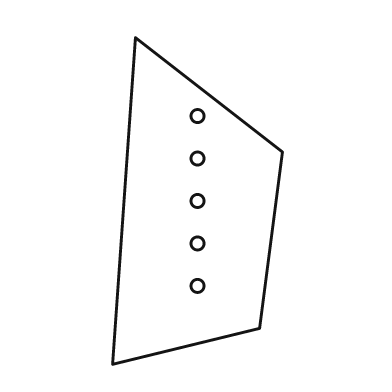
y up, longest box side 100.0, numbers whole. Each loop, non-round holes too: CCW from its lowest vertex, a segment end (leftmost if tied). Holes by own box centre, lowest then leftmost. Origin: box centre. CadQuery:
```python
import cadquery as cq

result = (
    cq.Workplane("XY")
    .moveTo(-26.0, -50.0)
    .lineTo(19.0, -39.0)
    .lineTo(26.0, 15.0)
    .lineTo(-19.0, 50.0)
    .close()
    .moveTo(0.0, -26.0)
    .circle(2.0)
    .moveTo(0.0, -13.0)
    .circle(2.0)
    .moveTo(0.0, 0.0)
    .circle(2.0)
    .moveTo(0.0, 13.0)
    .circle(2.0)
    .moveTo(0.0, 26.0)
    .circle(2.0)
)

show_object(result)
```